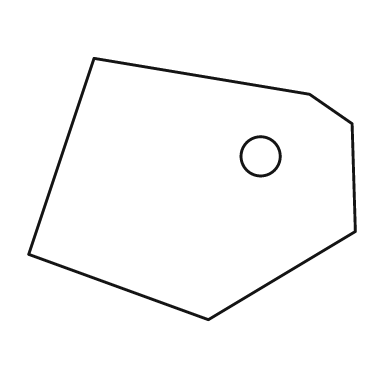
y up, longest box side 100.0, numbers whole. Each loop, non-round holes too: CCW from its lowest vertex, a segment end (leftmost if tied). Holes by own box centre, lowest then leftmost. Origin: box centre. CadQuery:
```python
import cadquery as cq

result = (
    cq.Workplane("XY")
    .moveTo(5.0, -40.0)
    .lineTo(50.0, -13.0)
    .lineTo(49.0, 20.0)
    .lineTo(36.0, 29.0)
    .lineTo(-30.0, 40.0)
    .lineTo(-50.0, -20.0)
    .close()
    .moveTo(21.0, 10.0)
    .circle(6.0)
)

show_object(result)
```